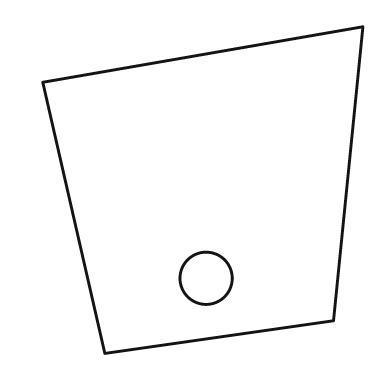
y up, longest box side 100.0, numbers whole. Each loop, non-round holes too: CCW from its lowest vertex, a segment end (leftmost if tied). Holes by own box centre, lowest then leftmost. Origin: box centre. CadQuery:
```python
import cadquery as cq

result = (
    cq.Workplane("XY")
    .moveTo(-30.0, -50.0)
    .lineTo(40.0, -40.0)
    .lineTo(49.0, 50.0)
    .lineTo(-49.0, 33.0)
    .close()
    .moveTo(1.0, -27.0)
    .circle(8.0)
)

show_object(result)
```